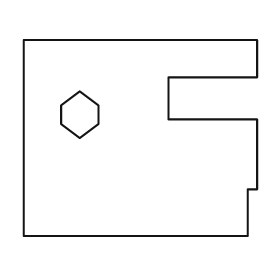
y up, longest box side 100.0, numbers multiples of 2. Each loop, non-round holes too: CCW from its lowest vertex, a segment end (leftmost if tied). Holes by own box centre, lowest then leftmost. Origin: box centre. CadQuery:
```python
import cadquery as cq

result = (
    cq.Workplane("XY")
    .moveTo(-50.0, -42.0)
    .lineTo(46.0, -42.0)
    .lineTo(46.0, -22.0)
    .lineTo(50.0, -22.0)
    .lineTo(50.0, 8.0)
    .lineTo(12.0, 8.0)
    .lineTo(12.0, 26.0)
    .lineTo(50.0, 26.0)
    .lineTo(50.0, 42.0)
    .lineTo(-50.0, 42.0)
    .close()
    .moveTo(-26.0, 0.0)
    .lineTo(-18.0, 6.0)
    .lineTo(-18.0, 14.0)
    .lineTo(-26.0, 20.0)
    .lineTo(-34.0, 14.0)
    .lineTo(-34.0, 6.0)
    .close()
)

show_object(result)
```